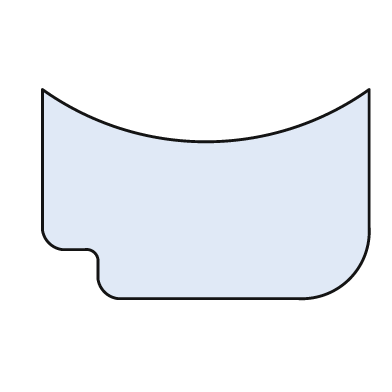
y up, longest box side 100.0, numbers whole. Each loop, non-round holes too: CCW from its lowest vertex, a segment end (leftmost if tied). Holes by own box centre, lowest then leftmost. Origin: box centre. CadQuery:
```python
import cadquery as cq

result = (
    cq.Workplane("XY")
    .moveTo(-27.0, -32.0)
    .lineTo(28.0, -32.0)
    .threePointArc((44.0, -26.0), (50.0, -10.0))
    .lineTo(50.0, 32.0)
    .threePointArc((0.0, 16.0), (-50.0, 32.0))
    .lineTo(-50.0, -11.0)
    .threePointArc((-48.0, -15.0), (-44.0, -17.0))
    .lineTo(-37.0, -17.0)
    .threePointArc((-34.0, -18.0), (-33.0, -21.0))
    .lineTo(-33.0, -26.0)
    .threePointArc((-31.0, -30.0), (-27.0, -32.0))
    .close()
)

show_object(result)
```